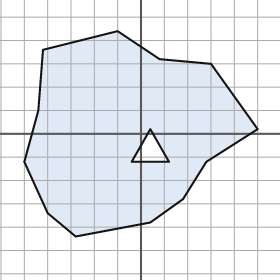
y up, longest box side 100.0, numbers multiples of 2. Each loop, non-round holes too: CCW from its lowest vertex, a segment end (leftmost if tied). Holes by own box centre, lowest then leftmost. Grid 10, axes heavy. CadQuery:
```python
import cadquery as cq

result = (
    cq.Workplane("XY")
    .moveTo(-28.0, -44.0)
    .lineTo(4.0, -38.0)
    .lineTo(18.0, -28.0)
    .lineTo(28.0, -12.0)
    .lineTo(50.0, 2.0)
    .lineTo(30.0, 30.0)
    .lineTo(8.0, 32.0)
    .lineTo(-10.0, 44.0)
    .lineTo(-42.0, 36.0)
    .lineTo(-44.0, 10.0)
    .lineTo(-50.0, -12.0)
    .lineTo(-40.0, -34.0)
    .close()
    .moveTo(-4.0, -12.0)
    .lineTo(12.0, -12.0)
    .lineTo(4.0, 2.0)
    .close()
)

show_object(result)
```